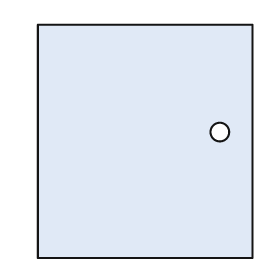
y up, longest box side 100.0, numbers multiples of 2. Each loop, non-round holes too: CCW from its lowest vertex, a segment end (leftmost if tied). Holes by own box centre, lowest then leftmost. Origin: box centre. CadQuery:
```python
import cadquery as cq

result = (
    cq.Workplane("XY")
    .moveTo(-46.0, -50.0)
    .lineTo(46.0, -50.0)
    .lineTo(46.0, 50.0)
    .lineTo(-46.0, 50.0)
    .close()
    .moveTo(32.0, 4.0)
    .circle(4.0)
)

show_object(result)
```